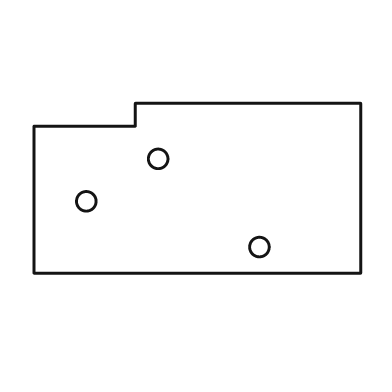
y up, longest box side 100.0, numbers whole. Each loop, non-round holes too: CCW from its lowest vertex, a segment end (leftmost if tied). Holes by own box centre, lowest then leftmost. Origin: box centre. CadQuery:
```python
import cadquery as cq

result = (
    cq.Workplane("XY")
    .moveTo(-50.0, -26.0)
    .lineTo(50.0, -26.0)
    .lineTo(50.0, 26.0)
    .lineTo(-19.0, 26.0)
    .lineTo(-19.0, 19.0)
    .lineTo(-50.0, 19.0)
    .close()
    .moveTo(19.0, -18.0)
    .circle(3.0)
    .moveTo(-34.0, -4.0)
    .circle(3.0)
    .moveTo(-12.0, 9.0)
    .circle(3.0)
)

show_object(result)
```